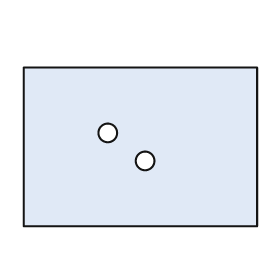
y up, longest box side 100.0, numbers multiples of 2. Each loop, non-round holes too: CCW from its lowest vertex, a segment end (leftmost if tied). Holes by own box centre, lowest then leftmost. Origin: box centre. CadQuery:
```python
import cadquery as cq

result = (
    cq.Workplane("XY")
    .moveTo(-50.0, -34.0)
    .lineTo(50.0, -34.0)
    .lineTo(50.0, 34.0)
    .lineTo(-50.0, 34.0)
    .close()
    .moveTo(2.0, -6.0)
    .circle(4.0)
    .moveTo(-14.0, 6.0)
    .circle(4.0)
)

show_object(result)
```